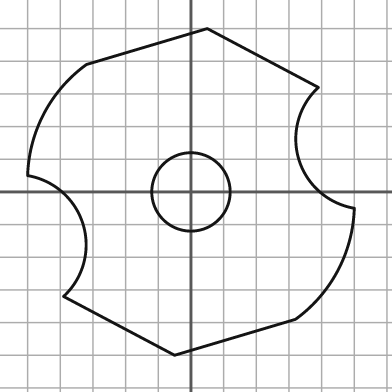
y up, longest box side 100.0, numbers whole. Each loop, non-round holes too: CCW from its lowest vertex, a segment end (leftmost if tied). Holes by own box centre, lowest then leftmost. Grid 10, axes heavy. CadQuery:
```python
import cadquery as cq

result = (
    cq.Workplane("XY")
    .moveTo(-5.0, -50.0)
    .lineTo(32.0, -39.0)
    .threePointArc((45.0, -24.0), (50.0, -5.0))
    .threePointArc((33.0, 10.0), (39.0, 32.0))
    .lineTo(5.0, 50.0)
    .lineTo(-32.0, 39.0)
    .threePointArc((-45.0, 24.0), (-50.0, 5.0))
    .threePointArc((-33.0, -10.0), (-39.0, -32.0))
    .close()
    .moveTo(0.0, 0.0)
    .circle(12.0)
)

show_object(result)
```